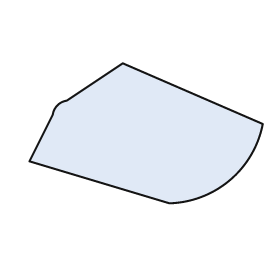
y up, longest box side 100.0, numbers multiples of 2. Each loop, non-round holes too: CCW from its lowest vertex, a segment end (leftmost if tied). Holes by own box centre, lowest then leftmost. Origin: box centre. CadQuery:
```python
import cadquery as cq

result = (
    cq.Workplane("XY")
    .moveTo(10.0, -30.0)
    .threePointArc((36.0, -20.0), (50.0, 4.0))
    .lineTo(-10.0, 30.0)
    .lineTo(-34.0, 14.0)
    .threePointArc((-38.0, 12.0), (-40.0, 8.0))
    .lineTo(-50.0, -12.0)
    .close()
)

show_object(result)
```